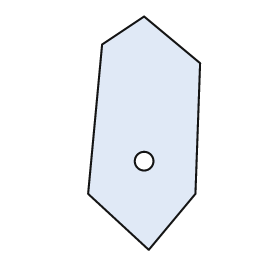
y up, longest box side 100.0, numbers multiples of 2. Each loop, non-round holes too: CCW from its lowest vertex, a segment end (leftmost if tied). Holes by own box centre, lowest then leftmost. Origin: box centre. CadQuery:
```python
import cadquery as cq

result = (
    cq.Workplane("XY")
    .moveTo(2.0, -50.0)
    .lineTo(22.0, -26.0)
    .lineTo(24.0, 30.0)
    .lineTo(0.0, 50.0)
    .lineTo(-18.0, 38.0)
    .lineTo(-24.0, -26.0)
    .close()
    .moveTo(0.0, -12.0)
    .circle(4.0)
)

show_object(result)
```